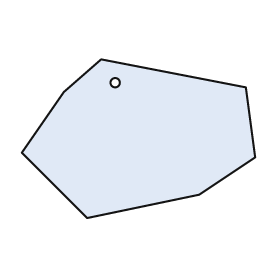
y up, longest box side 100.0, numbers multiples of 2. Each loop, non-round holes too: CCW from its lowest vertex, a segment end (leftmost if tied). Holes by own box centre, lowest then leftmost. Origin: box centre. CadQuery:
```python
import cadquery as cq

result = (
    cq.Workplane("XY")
    .moveTo(-22.0, -34.0)
    .lineTo(26.0, -24.0)
    .lineTo(50.0, -8.0)
    .lineTo(46.0, 22.0)
    .lineTo(-16.0, 34.0)
    .lineTo(-32.0, 20.0)
    .lineTo(-50.0, -6.0)
    .close()
    .moveTo(-10.0, 24.0)
    .circle(2.0)
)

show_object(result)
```